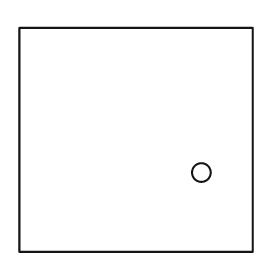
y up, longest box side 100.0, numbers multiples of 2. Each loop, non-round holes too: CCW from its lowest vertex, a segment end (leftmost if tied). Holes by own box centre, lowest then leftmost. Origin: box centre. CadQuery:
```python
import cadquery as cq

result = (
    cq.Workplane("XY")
    .moveTo(-50.0, -48.0)
    .lineTo(50.0, -48.0)
    .lineTo(50.0, 48.0)
    .lineTo(-50.0, 48.0)
    .close()
    .moveTo(28.0, -14.0)
    .circle(4.0)
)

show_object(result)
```